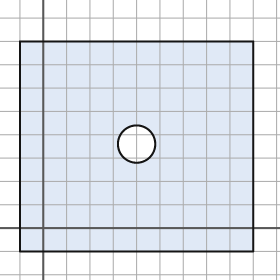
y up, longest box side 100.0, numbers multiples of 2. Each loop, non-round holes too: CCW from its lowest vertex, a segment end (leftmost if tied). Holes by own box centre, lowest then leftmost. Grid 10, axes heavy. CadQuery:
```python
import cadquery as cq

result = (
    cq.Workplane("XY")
    .moveTo(-10.0, -10.0)
    .lineTo(90.0, -10.0)
    .lineTo(90.0, 80.0)
    .lineTo(-10.0, 80.0)
    .close()
    .moveTo(40.0, 36.0)
    .circle(8.0)
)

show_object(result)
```